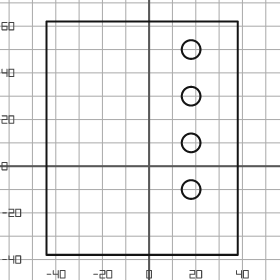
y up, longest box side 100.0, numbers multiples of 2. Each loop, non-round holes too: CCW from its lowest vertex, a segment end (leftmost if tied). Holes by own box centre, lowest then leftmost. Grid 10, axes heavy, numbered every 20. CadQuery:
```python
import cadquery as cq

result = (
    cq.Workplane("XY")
    .moveTo(-44.0, -38.0)
    .lineTo(38.0, -38.0)
    .lineTo(38.0, 62.0)
    .lineTo(-44.0, 62.0)
    .close()
    .moveTo(18.0, -10.0)
    .circle(4.0)
    .moveTo(18.0, 10.0)
    .circle(4.0)
    .moveTo(18.0, 30.0)
    .circle(4.0)
    .moveTo(18.0, 50.0)
    .circle(4.0)
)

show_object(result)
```